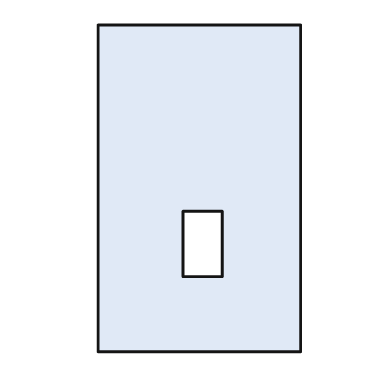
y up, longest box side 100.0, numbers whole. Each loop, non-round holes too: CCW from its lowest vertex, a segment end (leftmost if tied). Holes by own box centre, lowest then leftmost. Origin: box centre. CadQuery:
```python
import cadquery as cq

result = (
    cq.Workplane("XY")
    .moveTo(-31.0, -50.0)
    .lineTo(31.0, -50.0)
    .lineTo(31.0, 50.0)
    .lineTo(-31.0, 50.0)
    .close()
    .moveTo(-5.0, -27.0)
    .lineTo(7.0, -27.0)
    .lineTo(7.0, -7.0)
    .lineTo(-5.0, -7.0)
    .close()
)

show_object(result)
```